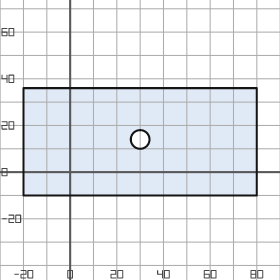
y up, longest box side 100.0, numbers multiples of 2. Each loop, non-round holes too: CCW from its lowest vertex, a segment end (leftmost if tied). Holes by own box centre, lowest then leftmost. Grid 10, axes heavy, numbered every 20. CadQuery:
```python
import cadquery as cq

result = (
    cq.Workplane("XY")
    .moveTo(-20.0, -10.0)
    .lineTo(80.0, -10.0)
    .lineTo(80.0, 36.0)
    .lineTo(-20.0, 36.0)
    .close()
    .moveTo(30.0, 14.0)
    .circle(4.0)
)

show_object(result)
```